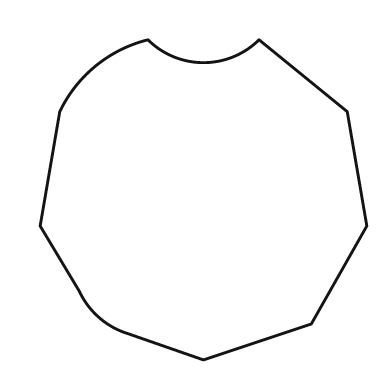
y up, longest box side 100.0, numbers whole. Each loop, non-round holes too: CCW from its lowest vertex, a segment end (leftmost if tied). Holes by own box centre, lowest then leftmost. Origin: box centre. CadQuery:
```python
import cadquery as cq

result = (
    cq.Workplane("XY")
    .moveTo(0.0, -49.0)
    .lineTo(33.0, -38.0)
    .lineTo(50.0, -8.0)
    .lineTo(44.0, 27.0)
    .lineTo(17.0, 49.0)
    .threePointArc((0.0, 42.0), (-17.0, 49.0))
    .threePointArc((-33.0, 41.0), (-44.0, 27.0))
    .lineTo(-50.0, -8.0)
    .lineTo(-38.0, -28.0)
    .threePointArc((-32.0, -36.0), (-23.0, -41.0))
    .close()
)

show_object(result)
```